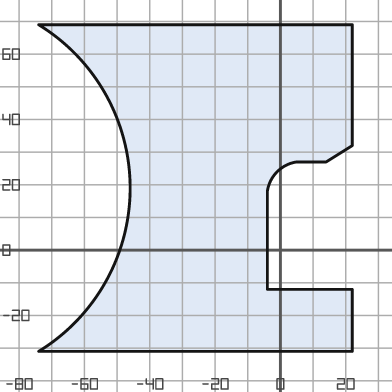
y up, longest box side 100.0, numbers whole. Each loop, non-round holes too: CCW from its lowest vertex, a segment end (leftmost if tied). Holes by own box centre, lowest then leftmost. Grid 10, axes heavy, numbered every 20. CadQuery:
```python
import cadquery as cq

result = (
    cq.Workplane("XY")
    .moveTo(-74.0, -31.0)
    .lineTo(22.0, -31.0)
    .lineTo(22.0, -12.0)
    .lineTo(-4.0, -12.0)
    .lineTo(-4.0, 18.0)
    .threePointArc((-1.0, 24.0), (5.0, 27.0))
    .lineTo(14.0, 27.0)
    .lineTo(22.0, 32.0)
    .lineTo(22.0, 69.0)
    .lineTo(-74.0, 69.0)
    .threePointArc((-46.0, 19.0), (-74.0, -31.0))
    .close()
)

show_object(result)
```